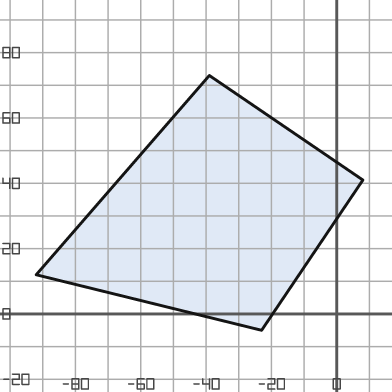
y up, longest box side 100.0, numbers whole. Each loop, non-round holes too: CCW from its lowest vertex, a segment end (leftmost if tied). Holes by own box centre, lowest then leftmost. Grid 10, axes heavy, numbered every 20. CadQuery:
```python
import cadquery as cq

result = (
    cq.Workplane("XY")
    .moveTo(-23.0, -5.0)
    .lineTo(8.0, 41.0)
    .lineTo(-39.0, 73.0)
    .lineTo(-92.0, 12.0)
    .close()
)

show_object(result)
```